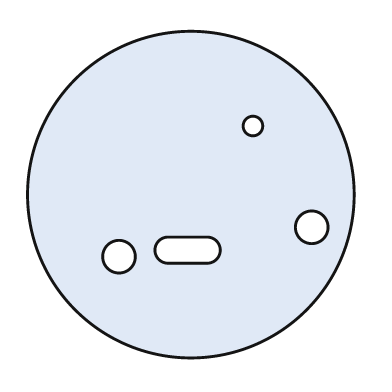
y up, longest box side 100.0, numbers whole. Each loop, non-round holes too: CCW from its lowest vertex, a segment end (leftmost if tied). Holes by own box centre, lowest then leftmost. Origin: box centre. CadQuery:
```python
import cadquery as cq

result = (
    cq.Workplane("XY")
    .moveTo(0.0, 0.0)
    .circle(50.0)
    .moveTo(-22.0, -19.0)
    .circle(5.0)
    .moveTo(-7.0, -21.0)
    .lineTo(5.0, -21.0)
    .threePointArc((9.0, -17.0), (5.0, -13.0))
    .lineTo(-7.0, -13.0)
    .threePointArc((-11.0, -17.0), (-7.0, -21.0))
    .close()
    .moveTo(37.0, -10.0)
    .circle(5.0)
    .moveTo(19.0, 21.0)
    .circle(3.0)
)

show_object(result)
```